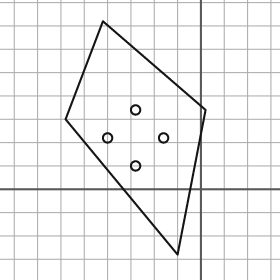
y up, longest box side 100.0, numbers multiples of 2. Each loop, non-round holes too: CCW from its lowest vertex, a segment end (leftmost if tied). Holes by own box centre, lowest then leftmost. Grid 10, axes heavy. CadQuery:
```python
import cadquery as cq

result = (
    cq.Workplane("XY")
    .moveTo(-10.0, -28.0)
    .lineTo(2.0, 34.0)
    .lineTo(-42.0, 72.0)
    .lineTo(-58.0, 30.0)
    .close()
    .moveTo(-28.0, 10.0)
    .circle(2.0)
    .moveTo(-40.0, 22.0)
    .circle(2.0)
    .moveTo(-16.0, 22.0)
    .circle(2.0)
    .moveTo(-28.0, 34.0)
    .circle(2.0)
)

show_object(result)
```